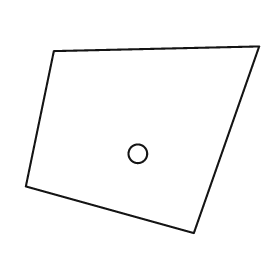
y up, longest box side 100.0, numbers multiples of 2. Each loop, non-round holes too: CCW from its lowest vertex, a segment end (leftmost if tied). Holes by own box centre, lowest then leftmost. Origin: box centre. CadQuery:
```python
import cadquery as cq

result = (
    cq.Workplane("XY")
    .moveTo(22.0, -40.0)
    .lineTo(50.0, 40.0)
    .lineTo(-38.0, 38.0)
    .lineTo(-50.0, -20.0)
    .close()
    .moveTo(-2.0, -6.0)
    .circle(4.0)
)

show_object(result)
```